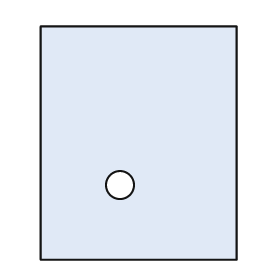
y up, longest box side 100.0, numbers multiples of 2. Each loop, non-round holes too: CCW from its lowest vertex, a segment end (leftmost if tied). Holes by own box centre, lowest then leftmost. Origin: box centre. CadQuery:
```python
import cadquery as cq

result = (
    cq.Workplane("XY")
    .moveTo(-42.0, -50.0)
    .lineTo(42.0, -50.0)
    .lineTo(42.0, 50.0)
    .lineTo(-42.0, 50.0)
    .close()
    .moveTo(-8.0, -18.0)
    .circle(6.0)
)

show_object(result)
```